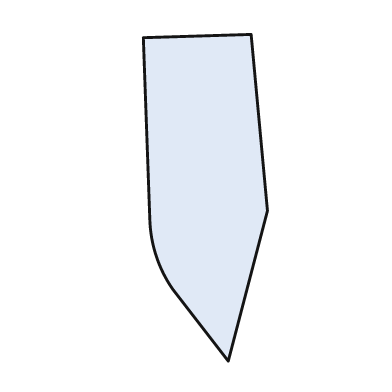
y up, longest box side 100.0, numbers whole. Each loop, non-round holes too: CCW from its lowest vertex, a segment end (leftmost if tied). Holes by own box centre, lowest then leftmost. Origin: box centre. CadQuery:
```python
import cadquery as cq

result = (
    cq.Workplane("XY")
    .moveTo(7.0, -50.0)
    .lineTo(19.0, -4.0)
    .lineTo(14.0, 50.0)
    .lineTo(-19.0, 49.0)
    .lineTo(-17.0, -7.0)
    .threePointArc((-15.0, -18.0), (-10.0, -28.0))
    .close()
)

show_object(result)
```